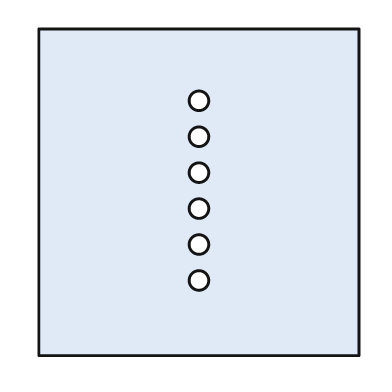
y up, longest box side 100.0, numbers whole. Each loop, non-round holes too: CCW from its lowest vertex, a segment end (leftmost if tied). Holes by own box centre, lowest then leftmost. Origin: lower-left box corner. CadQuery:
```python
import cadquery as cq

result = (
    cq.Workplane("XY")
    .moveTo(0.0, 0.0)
    .lineTo(98.0, 0.0)
    .lineTo(98.0, 100.0)
    .lineTo(0.0, 100.0)
    .close()
    .moveTo(49.0, 23.0)
    .circle(3.0)
    .moveTo(49.0, 34.0)
    .circle(3.0)
    .moveTo(49.0, 45.0)
    .circle(3.0)
    .moveTo(49.0, 56.0)
    .circle(3.0)
    .moveTo(49.0, 67.0)
    .circle(3.0)
    .moveTo(49.0, 78.0)
    .circle(3.0)
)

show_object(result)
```